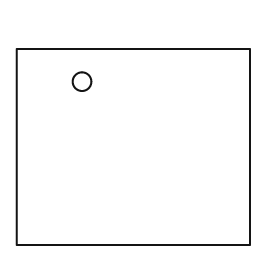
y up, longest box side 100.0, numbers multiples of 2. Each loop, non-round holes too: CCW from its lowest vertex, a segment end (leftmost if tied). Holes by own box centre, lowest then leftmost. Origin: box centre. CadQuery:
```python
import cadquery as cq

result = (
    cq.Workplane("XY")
    .moveTo(-50.0, -42.0)
    .lineTo(50.0, -42.0)
    .lineTo(50.0, 42.0)
    .lineTo(-50.0, 42.0)
    .close()
    .moveTo(-22.0, 28.0)
    .circle(4.0)
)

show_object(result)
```